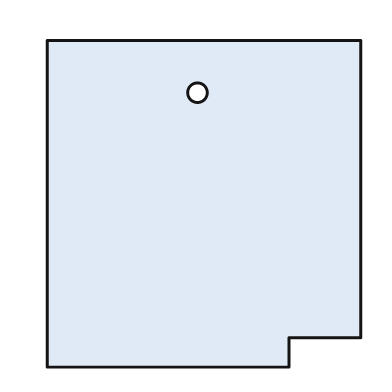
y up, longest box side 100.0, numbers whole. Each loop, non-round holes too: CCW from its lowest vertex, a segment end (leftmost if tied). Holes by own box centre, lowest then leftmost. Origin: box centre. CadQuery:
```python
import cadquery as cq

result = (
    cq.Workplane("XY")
    .moveTo(-48.0, -50.0)
    .lineTo(26.0, -50.0)
    .lineTo(26.0, -41.0)
    .lineTo(48.0, -41.0)
    .lineTo(48.0, 50.0)
    .lineTo(-48.0, 50.0)
    .close()
    .moveTo(-2.0, 34.0)
    .circle(3.0)
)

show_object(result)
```